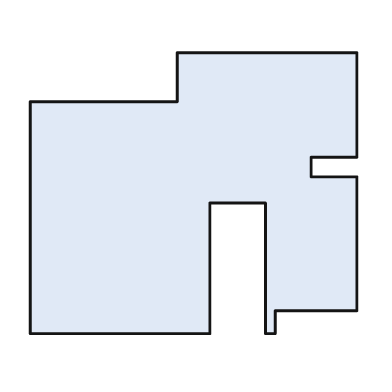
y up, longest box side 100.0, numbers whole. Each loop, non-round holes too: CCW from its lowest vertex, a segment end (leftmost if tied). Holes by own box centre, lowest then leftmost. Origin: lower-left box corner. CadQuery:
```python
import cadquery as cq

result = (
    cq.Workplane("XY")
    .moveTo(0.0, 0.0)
    .lineTo(55.0, 0.0)
    .lineTo(55.0, 40.0)
    .lineTo(72.0, 40.0)
    .lineTo(72.0, 0.0)
    .lineTo(75.0, 0.0)
    .lineTo(75.0, 7.0)
    .lineTo(100.0, 7.0)
    .lineTo(100.0, 48.0)
    .lineTo(86.0, 48.0)
    .lineTo(86.0, 54.0)
    .lineTo(100.0, 54.0)
    .lineTo(100.0, 86.0)
    .lineTo(45.0, 86.0)
    .lineTo(45.0, 71.0)
    .lineTo(0.0, 71.0)
    .close()
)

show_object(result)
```